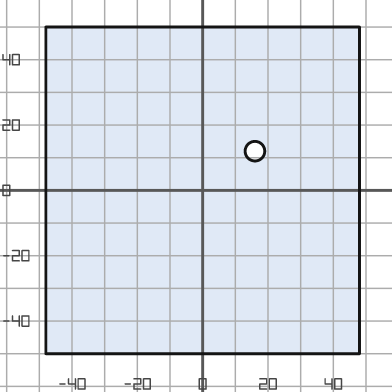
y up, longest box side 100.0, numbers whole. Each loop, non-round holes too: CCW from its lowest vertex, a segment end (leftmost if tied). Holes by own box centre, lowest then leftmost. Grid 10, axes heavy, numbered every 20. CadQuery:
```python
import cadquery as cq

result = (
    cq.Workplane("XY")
    .moveTo(-48.0, -50.0)
    .lineTo(48.0, -50.0)
    .lineTo(48.0, 50.0)
    .lineTo(-48.0, 50.0)
    .close()
    .moveTo(16.0, 12.0)
    .circle(3.0)
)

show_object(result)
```